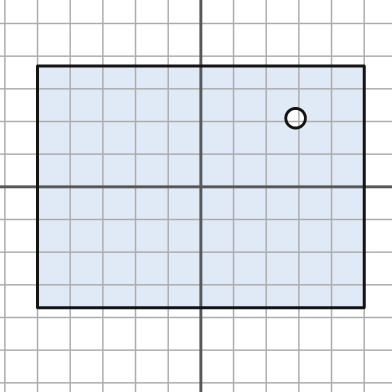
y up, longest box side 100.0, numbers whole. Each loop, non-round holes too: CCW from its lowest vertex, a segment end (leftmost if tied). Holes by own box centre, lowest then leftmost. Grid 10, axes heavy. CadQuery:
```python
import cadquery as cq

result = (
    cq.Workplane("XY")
    .moveTo(-50.0, -37.0)
    .lineTo(50.0, -37.0)
    .lineTo(50.0, 37.0)
    .lineTo(-50.0, 37.0)
    .close()
    .moveTo(29.0, 21.0)
    .circle(3.0)
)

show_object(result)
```